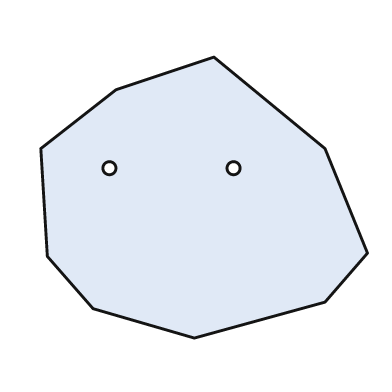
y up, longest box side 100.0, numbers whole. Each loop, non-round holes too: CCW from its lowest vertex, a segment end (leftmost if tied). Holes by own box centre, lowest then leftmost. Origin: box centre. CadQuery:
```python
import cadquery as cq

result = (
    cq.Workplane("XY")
    .moveTo(-3.0, -43.0)
    .lineTo(37.0, -32.0)
    .lineTo(50.0, -17.0)
    .lineTo(37.0, 15.0)
    .lineTo(3.0, 43.0)
    .lineTo(-27.0, 33.0)
    .lineTo(-50.0, 15.0)
    .lineTo(-48.0, -18.0)
    .lineTo(-34.0, -34.0)
    .close()
    .moveTo(-29.0, 9.0)
    .circle(2.0)
    .moveTo(9.0, 9.0)
    .circle(2.0)
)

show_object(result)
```